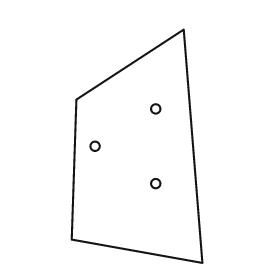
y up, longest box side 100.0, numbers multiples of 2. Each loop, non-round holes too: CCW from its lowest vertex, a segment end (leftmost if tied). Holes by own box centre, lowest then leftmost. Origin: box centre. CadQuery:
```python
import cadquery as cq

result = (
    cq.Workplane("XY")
    .moveTo(28.0, -50.0)
    .lineTo(20.0, 50.0)
    .lineTo(-26.0, 20.0)
    .lineTo(-28.0, -40.0)
    .close()
    .moveTo(8.0, -16.0)
    .circle(2.0)
    .moveTo(-18.0, 0.0)
    .circle(2.0)
    .moveTo(8.0, 16.0)
    .circle(2.0)
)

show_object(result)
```